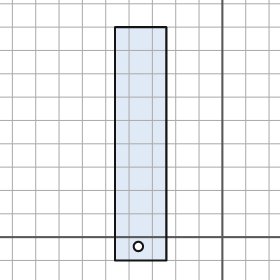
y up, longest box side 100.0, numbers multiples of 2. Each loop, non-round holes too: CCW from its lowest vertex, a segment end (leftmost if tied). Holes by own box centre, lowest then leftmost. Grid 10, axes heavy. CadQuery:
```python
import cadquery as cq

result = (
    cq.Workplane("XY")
    .moveTo(-46.0, -10.0)
    .lineTo(-24.0, -10.0)
    .lineTo(-24.0, 90.0)
    .lineTo(-46.0, 90.0)
    .close()
    .moveTo(-36.0, -4.0)
    .circle(2.0)
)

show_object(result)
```